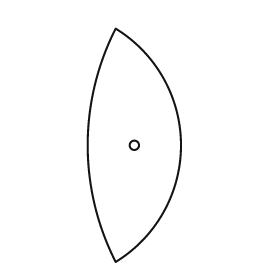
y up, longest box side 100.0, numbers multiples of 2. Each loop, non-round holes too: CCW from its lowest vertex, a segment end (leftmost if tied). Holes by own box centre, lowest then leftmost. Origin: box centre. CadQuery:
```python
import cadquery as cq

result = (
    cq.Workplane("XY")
    .moveTo(-8.0, -50.0)
    .threePointArc((20.0, 0.0), (-8.0, 50.0))
    .threePointArc((-20.0, 0.0), (-8.0, -50.0))
    .close()
    .moveTo(0.0, 0.0)
    .circle(2.0)
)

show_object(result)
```